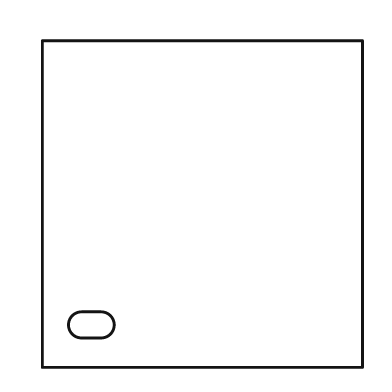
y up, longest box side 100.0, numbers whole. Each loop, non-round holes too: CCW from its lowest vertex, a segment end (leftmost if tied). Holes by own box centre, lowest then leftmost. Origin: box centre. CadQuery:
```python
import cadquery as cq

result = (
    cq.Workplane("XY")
    .moveTo(-49.0, -50.0)
    .lineTo(49.0, -50.0)
    .lineTo(49.0, 50.0)
    .lineTo(-49.0, 50.0)
    .close()
    .moveTo(-37.0, -41.0)
    .lineTo(-31.0, -41.0)
    .threePointArc((-27.0, -37.0), (-31.0, -33.0))
    .lineTo(-37.0, -33.0)
    .threePointArc((-41.0, -37.0), (-37.0, -41.0))
    .close()
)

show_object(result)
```